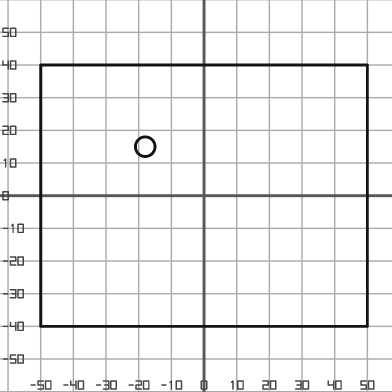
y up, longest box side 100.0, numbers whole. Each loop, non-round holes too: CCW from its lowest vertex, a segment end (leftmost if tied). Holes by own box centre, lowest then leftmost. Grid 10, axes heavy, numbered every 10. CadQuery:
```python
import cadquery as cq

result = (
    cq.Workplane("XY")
    .moveTo(-50.0, -40.0)
    .lineTo(50.0, -40.0)
    .lineTo(50.0, 40.0)
    .lineTo(-50.0, 40.0)
    .close()
    .moveTo(-18.0, 15.0)
    .circle(3.0)
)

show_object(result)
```